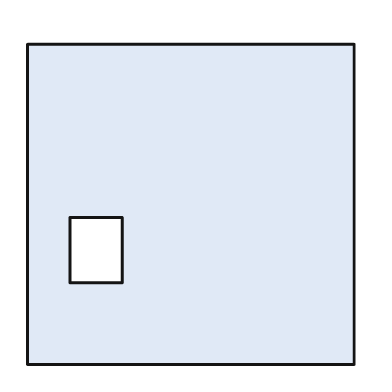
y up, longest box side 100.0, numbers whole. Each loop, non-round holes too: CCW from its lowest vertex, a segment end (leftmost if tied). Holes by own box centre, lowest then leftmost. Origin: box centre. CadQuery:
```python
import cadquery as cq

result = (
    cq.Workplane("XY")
    .moveTo(-50.0, -49.0)
    .lineTo(50.0, -49.0)
    .lineTo(50.0, 49.0)
    .lineTo(-50.0, 49.0)
    .close()
    .moveTo(-37.0, -24.0)
    .lineTo(-21.0, -24.0)
    .lineTo(-21.0, -4.0)
    .lineTo(-37.0, -4.0)
    .close()
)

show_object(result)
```